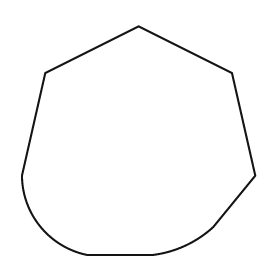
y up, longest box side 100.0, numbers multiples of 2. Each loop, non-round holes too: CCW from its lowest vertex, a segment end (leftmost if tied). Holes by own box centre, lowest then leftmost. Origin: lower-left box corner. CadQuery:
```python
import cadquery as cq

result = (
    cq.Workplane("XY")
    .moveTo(28.0, 0.0)
    .lineTo(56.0, 0.0)
    .threePointArc((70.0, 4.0), (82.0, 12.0))
    .lineTo(100.0, 34.0)
    .lineTo(90.0, 78.0)
    .lineTo(50.0, 98.0)
    .lineTo(10.0, 78.0)
    .lineTo(0.0, 34.0)
    .threePointArc((8.0, 12.0), (28.0, 0.0))
    .close()
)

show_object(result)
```